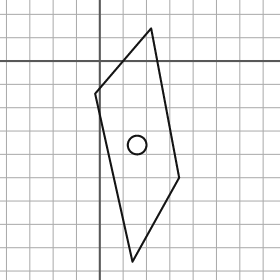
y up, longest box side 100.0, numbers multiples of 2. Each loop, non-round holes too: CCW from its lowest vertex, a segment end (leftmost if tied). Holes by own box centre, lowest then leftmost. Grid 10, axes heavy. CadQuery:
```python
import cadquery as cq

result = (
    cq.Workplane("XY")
    .moveTo(14.0, -86.0)
    .lineTo(34.0, -50.0)
    .lineTo(22.0, 14.0)
    .lineTo(-2.0, -14.0)
    .close()
    .moveTo(16.0, -36.0)
    .circle(4.0)
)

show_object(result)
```